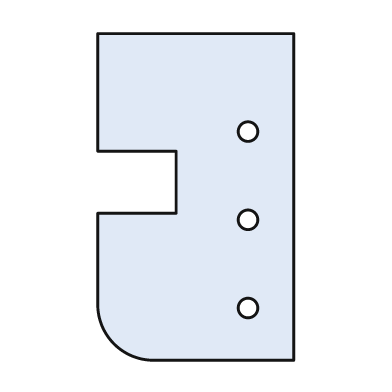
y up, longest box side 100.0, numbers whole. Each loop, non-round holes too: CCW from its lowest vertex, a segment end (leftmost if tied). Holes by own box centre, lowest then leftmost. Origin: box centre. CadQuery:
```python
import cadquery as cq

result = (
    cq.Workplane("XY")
    .moveTo(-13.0, -50.0)
    .lineTo(30.0, -50.0)
    .lineTo(30.0, 50.0)
    .lineTo(-30.0, 50.0)
    .lineTo(-30.0, 14.0)
    .lineTo(-6.0, 14.0)
    .lineTo(-6.0, -5.0)
    .lineTo(-30.0, -5.0)
    .lineTo(-30.0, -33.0)
    .threePointArc((-25.0, -45.0), (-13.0, -50.0))
    .close()
    .moveTo(16.0, -34.0)
    .circle(3.0)
    .moveTo(16.0, -7.0)
    .circle(3.0)
    .moveTo(16.0, 20.0)
    .circle(3.0)
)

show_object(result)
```